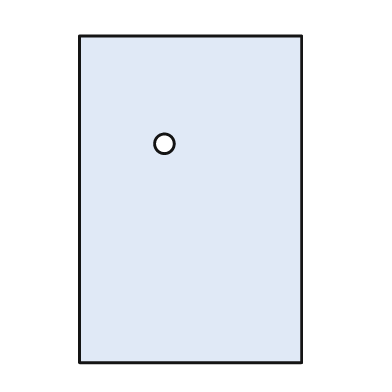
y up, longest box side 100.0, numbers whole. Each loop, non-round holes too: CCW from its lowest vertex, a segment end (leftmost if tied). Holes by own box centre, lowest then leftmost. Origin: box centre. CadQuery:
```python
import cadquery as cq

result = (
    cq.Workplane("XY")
    .moveTo(-34.0, -50.0)
    .lineTo(34.0, -50.0)
    .lineTo(34.0, 50.0)
    .lineTo(-34.0, 50.0)
    .close()
    .moveTo(-8.0, 17.0)
    .circle(3.0)
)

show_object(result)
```